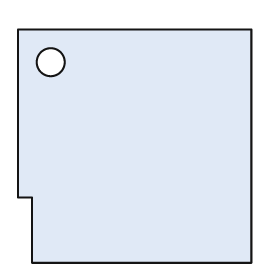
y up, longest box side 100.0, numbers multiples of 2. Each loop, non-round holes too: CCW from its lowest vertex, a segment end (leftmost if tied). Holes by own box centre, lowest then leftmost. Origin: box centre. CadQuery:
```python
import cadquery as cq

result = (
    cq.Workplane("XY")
    .moveTo(-44.0, -50.0)
    .lineTo(50.0, -50.0)
    .lineTo(50.0, 50.0)
    .lineTo(-50.0, 50.0)
    .lineTo(-50.0, -22.0)
    .lineTo(-44.0, -22.0)
    .close()
    .moveTo(-36.0, 36.0)
    .circle(6.0)
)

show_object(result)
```